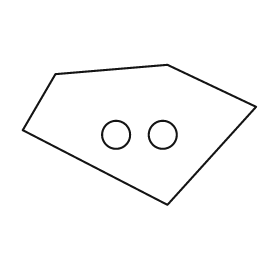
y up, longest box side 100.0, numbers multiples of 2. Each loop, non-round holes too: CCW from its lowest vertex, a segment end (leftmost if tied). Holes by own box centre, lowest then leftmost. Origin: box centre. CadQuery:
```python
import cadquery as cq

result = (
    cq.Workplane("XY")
    .moveTo(12.0, -30.0)
    .lineTo(50.0, 12.0)
    .lineTo(12.0, 30.0)
    .lineTo(-36.0, 26.0)
    .lineTo(-50.0, 2.0)
    .close()
    .moveTo(-10.0, 0.0)
    .circle(6.0)
    .moveTo(10.0, 0.0)
    .circle(6.0)
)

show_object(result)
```